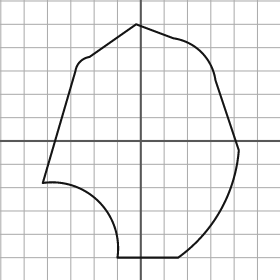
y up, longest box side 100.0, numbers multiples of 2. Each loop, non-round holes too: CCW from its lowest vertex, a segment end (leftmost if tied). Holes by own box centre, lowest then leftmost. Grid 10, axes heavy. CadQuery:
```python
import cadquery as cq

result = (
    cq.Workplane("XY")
    .moveTo(-10.0, -50.0)
    .lineTo(16.0, -50.0)
    .threePointArc((34.0, -30.0), (42.0, -4.0))
    .lineTo(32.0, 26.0)
    .threePointArc((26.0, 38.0), (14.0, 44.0))
    .lineTo(-2.0, 50.0)
    .lineTo(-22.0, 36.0)
    .threePointArc((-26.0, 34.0), (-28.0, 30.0))
    .lineTo(-42.0, -18.0)
    .threePointArc((-18.0, -26.0), (-10.0, -50.0))
    .close()
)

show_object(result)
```